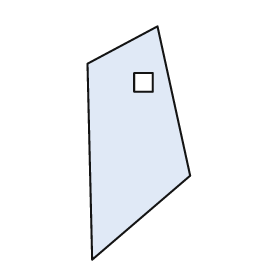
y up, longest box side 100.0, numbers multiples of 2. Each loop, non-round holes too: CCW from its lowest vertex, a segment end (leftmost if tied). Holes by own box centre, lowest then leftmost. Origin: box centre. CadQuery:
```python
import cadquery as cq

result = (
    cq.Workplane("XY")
    .moveTo(-20.0, -50.0)
    .lineTo(22.0, -14.0)
    .lineTo(8.0, 50.0)
    .lineTo(-22.0, 34.0)
    .close()
    .moveTo(-2.0, 22.0)
    .lineTo(6.0, 22.0)
    .lineTo(6.0, 30.0)
    .lineTo(-2.0, 30.0)
    .close()
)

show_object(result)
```